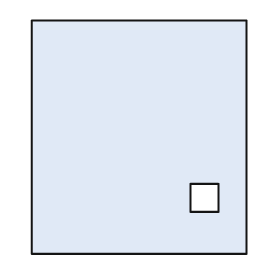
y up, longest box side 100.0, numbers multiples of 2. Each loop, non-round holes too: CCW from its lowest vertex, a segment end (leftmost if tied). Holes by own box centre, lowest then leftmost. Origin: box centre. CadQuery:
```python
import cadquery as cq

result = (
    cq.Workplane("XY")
    .moveTo(-46.0, -50.0)
    .lineTo(46.0, -50.0)
    .lineTo(46.0, 50.0)
    .lineTo(-46.0, 50.0)
    .close()
    .moveTo(22.0, -32.0)
    .lineTo(34.0, -32.0)
    .lineTo(34.0, -20.0)
    .lineTo(22.0, -20.0)
    .close()
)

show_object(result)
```